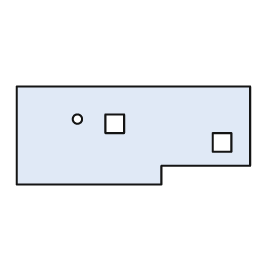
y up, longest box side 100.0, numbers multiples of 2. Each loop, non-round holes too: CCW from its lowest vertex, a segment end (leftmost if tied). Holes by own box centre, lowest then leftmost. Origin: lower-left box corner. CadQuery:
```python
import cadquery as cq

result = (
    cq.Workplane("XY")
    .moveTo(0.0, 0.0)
    .lineTo(62.0, 0.0)
    .lineTo(62.0, 8.0)
    .lineTo(100.0, 8.0)
    .lineTo(100.0, 42.0)
    .lineTo(0.0, 42.0)
    .close()
    .moveTo(84.0, 14.0)
    .lineTo(92.0, 14.0)
    .lineTo(92.0, 22.0)
    .lineTo(84.0, 22.0)
    .close()
    .moveTo(38.0, 22.0)
    .lineTo(46.0, 22.0)
    .lineTo(46.0, 30.0)
    .lineTo(38.0, 30.0)
    .close()
    .moveTo(26.0, 28.0)
    .circle(2.0)
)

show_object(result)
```